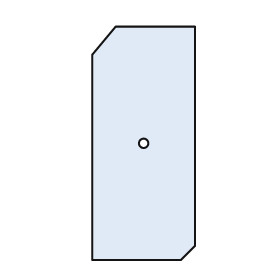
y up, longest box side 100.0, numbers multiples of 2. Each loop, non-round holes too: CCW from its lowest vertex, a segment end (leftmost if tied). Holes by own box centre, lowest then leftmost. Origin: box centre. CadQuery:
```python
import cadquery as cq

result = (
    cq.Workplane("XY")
    .moveTo(-22.0, -50.0)
    .lineTo(16.0, -50.0)
    .lineTo(22.0, -44.0)
    .lineTo(22.0, 50.0)
    .lineTo(-12.0, 50.0)
    .lineTo(-22.0, 38.0)
    .close()
    .moveTo(0.0, 0.0)
    .circle(2.0)
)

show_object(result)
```